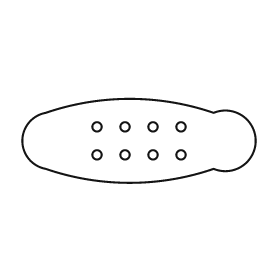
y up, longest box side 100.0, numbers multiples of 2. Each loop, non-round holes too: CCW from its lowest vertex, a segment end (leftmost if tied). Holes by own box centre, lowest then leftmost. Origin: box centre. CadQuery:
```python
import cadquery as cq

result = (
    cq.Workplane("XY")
    .moveTo(-40.0, -12.0)
    .threePointArc((-4.0, -18.0), (32.0, -12.0))
    .threePointArc((50.0, 0.0), (32.0, 12.0))
    .threePointArc((-4.0, 18.0), (-40.0, 12.0))
    .threePointArc((-50.0, 0.0), (-40.0, -12.0))
    .close()
    .moveTo(-18.0, -6.0)
    .circle(2.0)
    .moveTo(-6.0, -6.0)
    .circle(2.0)
    .moveTo(6.0, -6.0)
    .circle(2.0)
    .moveTo(18.0, -6.0)
    .circle(2.0)
    .moveTo(-18.0, 6.0)
    .circle(2.0)
    .moveTo(-6.0, 6.0)
    .circle(2.0)
    .moveTo(6.0, 6.0)
    .circle(2.0)
    .moveTo(18.0, 6.0)
    .circle(2.0)
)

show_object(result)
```